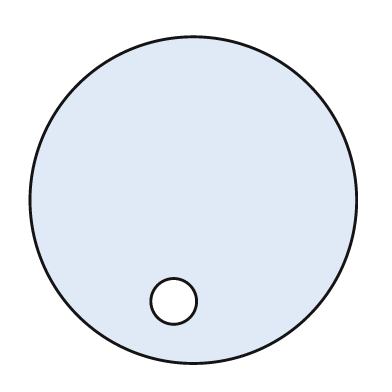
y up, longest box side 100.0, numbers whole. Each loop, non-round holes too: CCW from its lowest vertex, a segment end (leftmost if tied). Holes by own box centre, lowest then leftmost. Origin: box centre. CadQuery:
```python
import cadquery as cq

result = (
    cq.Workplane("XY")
    .moveTo(0.0, 0.0)
    .circle(50.0)
    .moveTo(-6.0, -31.0)
    .circle(7.0)
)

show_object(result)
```